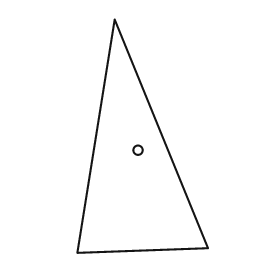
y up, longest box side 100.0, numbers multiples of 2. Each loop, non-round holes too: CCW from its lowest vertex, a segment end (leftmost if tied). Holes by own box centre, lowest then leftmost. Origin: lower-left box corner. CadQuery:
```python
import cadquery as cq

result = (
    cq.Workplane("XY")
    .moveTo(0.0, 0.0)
    .lineTo(56.0, 2.0)
    .lineTo(16.0, 100.0)
    .close()
    .moveTo(26.0, 44.0)
    .circle(2.0)
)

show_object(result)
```